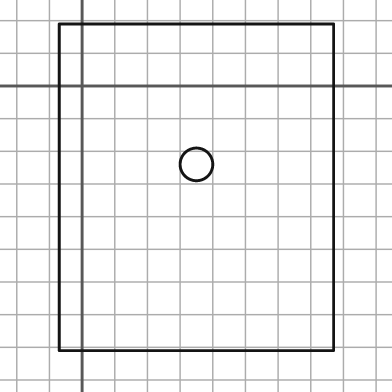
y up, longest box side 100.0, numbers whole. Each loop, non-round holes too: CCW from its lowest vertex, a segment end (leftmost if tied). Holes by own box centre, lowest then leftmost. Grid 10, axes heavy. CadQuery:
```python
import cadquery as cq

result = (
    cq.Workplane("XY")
    .moveTo(-7.0, -81.0)
    .lineTo(77.0, -81.0)
    .lineTo(77.0, 19.0)
    .lineTo(-7.0, 19.0)
    .close()
    .moveTo(35.0, -24.0)
    .circle(5.0)
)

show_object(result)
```